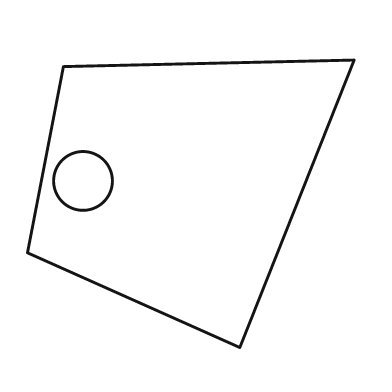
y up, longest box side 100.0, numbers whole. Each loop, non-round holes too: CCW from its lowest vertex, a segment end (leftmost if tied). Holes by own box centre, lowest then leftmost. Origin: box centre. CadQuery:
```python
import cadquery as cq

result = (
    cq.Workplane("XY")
    .moveTo(15.0, -44.0)
    .lineTo(50.0, 44.0)
    .lineTo(-39.0, 42.0)
    .lineTo(-50.0, -15.0)
    .close()
    .moveTo(-33.0, 7.0)
    .circle(9.0)
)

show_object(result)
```